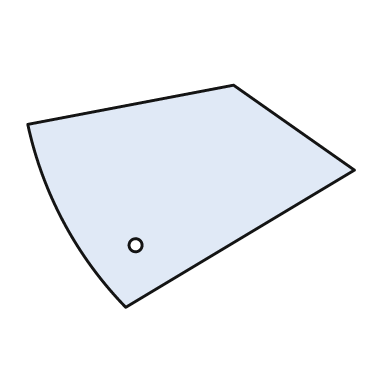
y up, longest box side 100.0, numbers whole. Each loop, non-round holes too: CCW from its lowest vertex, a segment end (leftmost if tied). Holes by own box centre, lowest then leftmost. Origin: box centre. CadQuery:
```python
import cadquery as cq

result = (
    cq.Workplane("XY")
    .moveTo(-20.0, -34.0)
    .lineTo(50.0, 8.0)
    .lineTo(13.0, 34.0)
    .lineTo(-50.0, 22.0)
    .threePointArc((-39.0, -8.0), (-20.0, -34.0))
    .close()
    .moveTo(-17.0, -15.0)
    .circle(2.0)
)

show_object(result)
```